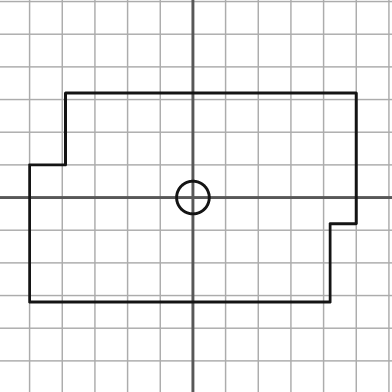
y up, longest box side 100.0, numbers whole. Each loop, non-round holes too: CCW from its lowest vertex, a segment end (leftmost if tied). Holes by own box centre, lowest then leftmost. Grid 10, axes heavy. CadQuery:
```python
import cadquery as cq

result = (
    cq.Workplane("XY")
    .moveTo(-50.0, -32.0)
    .lineTo(42.0, -32.0)
    .lineTo(42.0, -8.0)
    .lineTo(50.0, -8.0)
    .lineTo(50.0, 32.0)
    .lineTo(-39.0, 32.0)
    .lineTo(-39.0, 10.0)
    .lineTo(-50.0, 10.0)
    .close()
    .moveTo(0.0, 0.0)
    .circle(5.0)
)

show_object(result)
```